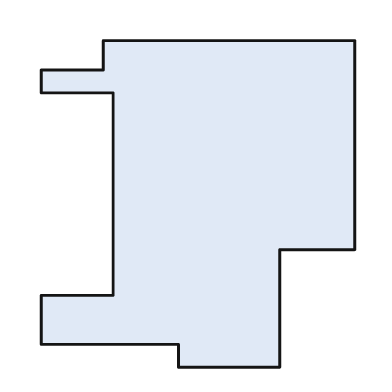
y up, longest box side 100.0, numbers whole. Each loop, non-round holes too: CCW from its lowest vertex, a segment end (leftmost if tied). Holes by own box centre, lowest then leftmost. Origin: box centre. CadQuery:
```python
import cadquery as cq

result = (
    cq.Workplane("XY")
    .moveTo(-6.0, -50.0)
    .lineTo(25.0, -50.0)
    .lineTo(25.0, -14.0)
    .lineTo(48.0, -14.0)
    .lineTo(48.0, 50.0)
    .lineTo(-29.0, 50.0)
    .lineTo(-29.0, 41.0)
    .lineTo(-48.0, 41.0)
    .lineTo(-48.0, 34.0)
    .lineTo(-26.0, 34.0)
    .lineTo(-26.0, -28.0)
    .lineTo(-48.0, -28.0)
    .lineTo(-48.0, -43.0)
    .lineTo(-6.0, -43.0)
    .close()
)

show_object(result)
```